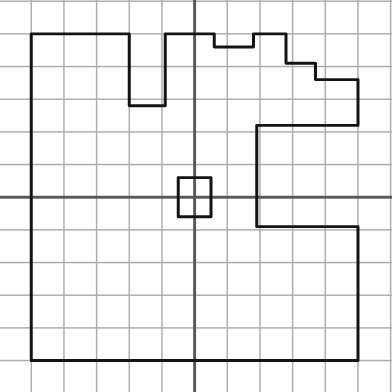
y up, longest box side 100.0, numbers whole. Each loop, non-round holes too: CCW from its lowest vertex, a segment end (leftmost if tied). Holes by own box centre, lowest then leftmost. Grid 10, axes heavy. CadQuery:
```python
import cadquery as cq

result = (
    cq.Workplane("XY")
    .moveTo(-50.0, -50.0)
    .lineTo(50.0, -50.0)
    .lineTo(50.0, -9.0)
    .lineTo(19.0, -9.0)
    .lineTo(19.0, 22.0)
    .lineTo(50.0, 22.0)
    .lineTo(50.0, 36.0)
    .lineTo(37.0, 36.0)
    .lineTo(37.0, 41.0)
    .lineTo(28.0, 41.0)
    .lineTo(28.0, 50.0)
    .lineTo(18.0, 50.0)
    .lineTo(18.0, 46.0)
    .lineTo(6.0, 46.0)
    .lineTo(6.0, 50.0)
    .lineTo(-9.0, 50.0)
    .lineTo(-9.0, 28.0)
    .lineTo(-20.0, 28.0)
    .lineTo(-20.0, 50.0)
    .lineTo(-50.0, 50.0)
    .close()
    .moveTo(-5.0, -6.0)
    .lineTo(5.0, -6.0)
    .lineTo(5.0, 6.0)
    .lineTo(-5.0, 6.0)
    .close()
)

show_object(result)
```